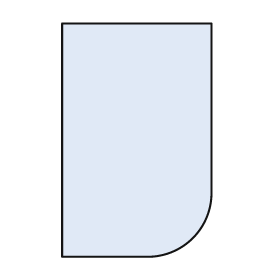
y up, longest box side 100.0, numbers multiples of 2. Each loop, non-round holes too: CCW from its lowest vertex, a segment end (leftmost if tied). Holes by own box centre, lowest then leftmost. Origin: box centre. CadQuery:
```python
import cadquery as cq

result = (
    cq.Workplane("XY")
    .moveTo(-32.0, -50.0)
    .lineTo(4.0, -50.0)
    .threePointArc((24.0, -42.0), (32.0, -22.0))
    .lineTo(32.0, 50.0)
    .lineTo(-32.0, 50.0)
    .close()
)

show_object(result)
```